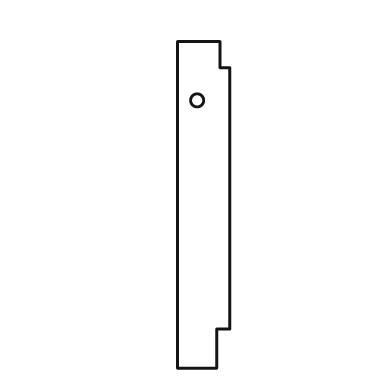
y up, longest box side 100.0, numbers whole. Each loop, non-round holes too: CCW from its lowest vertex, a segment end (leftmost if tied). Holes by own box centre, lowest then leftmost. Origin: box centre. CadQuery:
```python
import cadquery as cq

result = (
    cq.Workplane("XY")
    .moveTo(-8.0, -50.0)
    .lineTo(4.0, -50.0)
    .lineTo(4.0, -38.0)
    .lineTo(8.0, -38.0)
    .lineTo(8.0, 42.0)
    .lineTo(5.0, 42.0)
    .lineTo(5.0, 50.0)
    .lineTo(-8.0, 50.0)
    .close()
    .moveTo(-2.0, 32.0)
    .circle(2.0)
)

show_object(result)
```